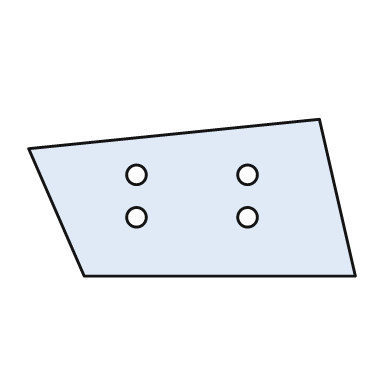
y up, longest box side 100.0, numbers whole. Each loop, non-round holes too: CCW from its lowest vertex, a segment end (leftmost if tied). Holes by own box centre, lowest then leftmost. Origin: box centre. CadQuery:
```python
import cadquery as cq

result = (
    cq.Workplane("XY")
    .moveTo(-33.0, -24.0)
    .lineTo(50.0, -24.0)
    .lineTo(39.0, 24.0)
    .lineTo(-50.0, 15.0)
    .close()
    .moveTo(-17.0, -6.0)
    .circle(3.0)
    .moveTo(17.0, -6.0)
    .circle(3.0)
    .moveTo(-17.0, 7.0)
    .circle(3.0)
    .moveTo(17.0, 7.0)
    .circle(3.0)
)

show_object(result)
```